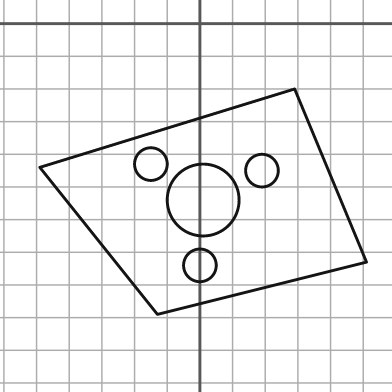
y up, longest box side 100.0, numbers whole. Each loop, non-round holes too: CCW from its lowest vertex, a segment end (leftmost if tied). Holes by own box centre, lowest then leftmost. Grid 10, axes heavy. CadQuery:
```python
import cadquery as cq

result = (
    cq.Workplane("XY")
    .moveTo(-13.0, -89.0)
    .lineTo(51.0, -73.0)
    .lineTo(29.0, -20.0)
    .lineTo(-49.0, -44.0)
    .close()
    .moveTo(0.0, -74.0)
    .circle(5.0)
    .moveTo(1.0, -54.0)
    .circle(11.0)
    .moveTo(19.0, -45.0)
    .circle(5.0)
    .moveTo(-15.0, -43.0)
    .circle(5.0)
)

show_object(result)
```